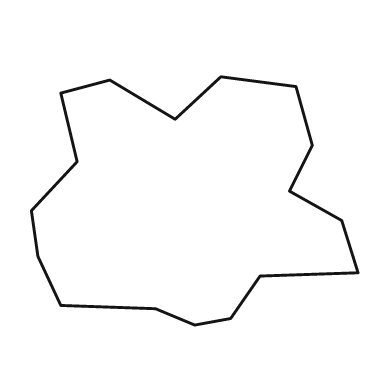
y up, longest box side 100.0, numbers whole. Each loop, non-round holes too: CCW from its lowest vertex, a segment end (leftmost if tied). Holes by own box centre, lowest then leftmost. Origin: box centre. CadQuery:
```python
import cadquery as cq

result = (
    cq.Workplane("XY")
    .moveTo(0.0, -38.0)
    .lineTo(11.0, -36.0)
    .lineTo(20.0, -23.0)
    .lineTo(50.0, -22.0)
    .lineTo(45.0, -6.0)
    .lineTo(29.0, 3.0)
    .lineTo(36.0, 17.0)
    .lineTo(31.0, 35.0)
    .lineTo(8.0, 38.0)
    .lineTo(-6.0, 25.0)
    .lineTo(-26.0, 37.0)
    .lineTo(-41.0, 33.0)
    .lineTo(-36.0, 12.0)
    .lineTo(-50.0, -3.0)
    .lineTo(-48.0, -17.0)
    .lineTo(-41.0, -32.0)
    .lineTo(-12.0, -33.0)
    .close()
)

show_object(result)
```